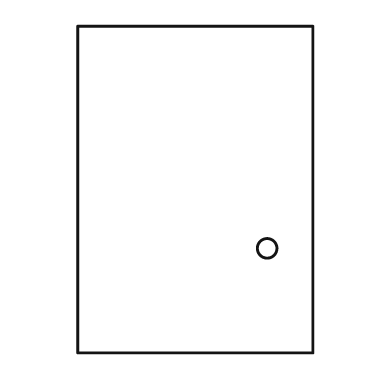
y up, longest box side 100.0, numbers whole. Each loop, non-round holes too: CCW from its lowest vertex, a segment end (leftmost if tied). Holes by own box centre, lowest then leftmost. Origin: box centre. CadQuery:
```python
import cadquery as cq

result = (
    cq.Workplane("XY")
    .moveTo(-36.0, -50.0)
    .lineTo(36.0, -50.0)
    .lineTo(36.0, 50.0)
    .lineTo(-36.0, 50.0)
    .close()
    .moveTo(22.0, -18.0)
    .circle(3.0)
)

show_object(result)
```